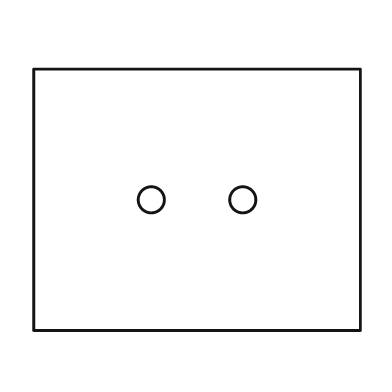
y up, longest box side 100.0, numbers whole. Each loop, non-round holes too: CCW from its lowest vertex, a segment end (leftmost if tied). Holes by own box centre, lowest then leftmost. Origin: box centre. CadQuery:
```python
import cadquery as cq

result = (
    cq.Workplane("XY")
    .moveTo(-50.0, -40.0)
    .lineTo(50.0, -40.0)
    .lineTo(50.0, 40.0)
    .lineTo(-50.0, 40.0)
    .close()
    .moveTo(-14.0, 0.0)
    .circle(4.0)
    .moveTo(14.0, 0.0)
    .circle(4.0)
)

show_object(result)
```